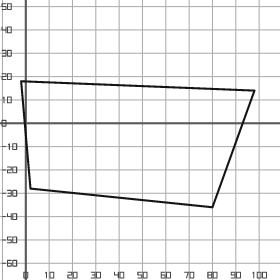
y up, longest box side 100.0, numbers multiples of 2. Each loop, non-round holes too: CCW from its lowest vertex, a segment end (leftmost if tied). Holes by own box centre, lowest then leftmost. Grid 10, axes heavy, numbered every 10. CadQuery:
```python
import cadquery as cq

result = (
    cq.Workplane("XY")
    .moveTo(80.0, -36.0)
    .lineTo(98.0, 14.0)
    .lineTo(-2.0, 18.0)
    .lineTo(2.0, -28.0)
    .close()
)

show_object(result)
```